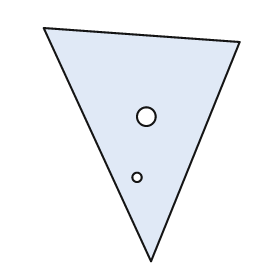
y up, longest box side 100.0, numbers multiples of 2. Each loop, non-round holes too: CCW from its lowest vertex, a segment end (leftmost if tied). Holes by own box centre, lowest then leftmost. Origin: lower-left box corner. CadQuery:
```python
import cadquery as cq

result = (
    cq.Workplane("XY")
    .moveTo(46.0, 0.0)
    .lineTo(84.0, 94.0)
    .lineTo(0.0, 100.0)
    .close()
    .moveTo(40.0, 36.0)
    .circle(2.0)
    .moveTo(44.0, 62.0)
    .circle(4.0)
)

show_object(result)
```